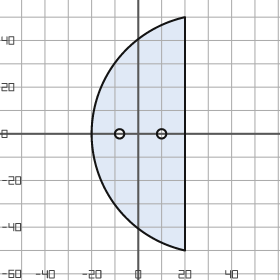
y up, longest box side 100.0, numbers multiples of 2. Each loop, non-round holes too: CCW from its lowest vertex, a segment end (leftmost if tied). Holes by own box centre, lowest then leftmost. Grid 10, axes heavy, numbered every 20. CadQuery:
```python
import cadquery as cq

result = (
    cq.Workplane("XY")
    .moveTo(20.0, -50.0)
    .lineTo(20.0, 50.0)
    .threePointArc((-20.0, 0.0), (20.0, -50.0))
    .close()
    .moveTo(-8.0, 0.0)
    .circle(2.0)
    .moveTo(10.0, 0.0)
    .circle(2.0)
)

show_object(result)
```